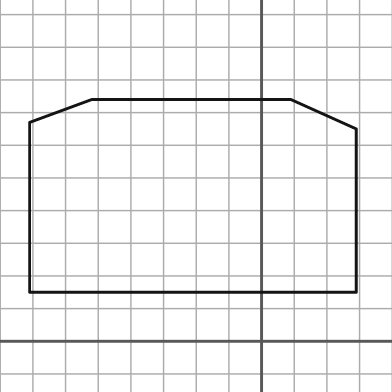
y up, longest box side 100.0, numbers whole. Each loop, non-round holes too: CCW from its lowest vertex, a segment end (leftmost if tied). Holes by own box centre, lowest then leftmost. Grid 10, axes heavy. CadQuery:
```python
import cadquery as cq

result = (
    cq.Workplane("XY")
    .moveTo(-71.0, 15.0)
    .lineTo(29.0, 15.0)
    .lineTo(29.0, 65.0)
    .lineTo(9.0, 74.0)
    .lineTo(-52.0, 74.0)
    .lineTo(-71.0, 67.0)
    .close()
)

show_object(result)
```